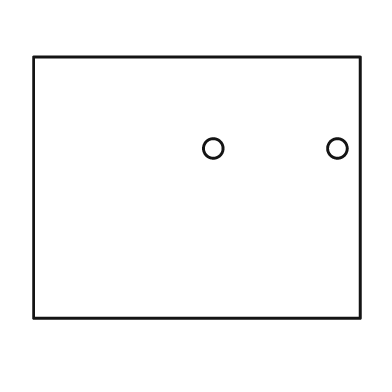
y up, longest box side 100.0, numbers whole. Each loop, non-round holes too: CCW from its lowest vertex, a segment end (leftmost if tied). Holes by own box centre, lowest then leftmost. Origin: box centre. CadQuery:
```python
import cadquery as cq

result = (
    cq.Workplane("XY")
    .moveTo(-50.0, -40.0)
    .lineTo(50.0, -40.0)
    .lineTo(50.0, 40.0)
    .lineTo(-50.0, 40.0)
    .close()
    .moveTo(5.0, 12.0)
    .circle(3.0)
    .moveTo(43.0, 12.0)
    .circle(3.0)
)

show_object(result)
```